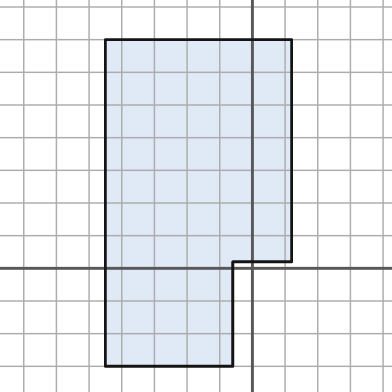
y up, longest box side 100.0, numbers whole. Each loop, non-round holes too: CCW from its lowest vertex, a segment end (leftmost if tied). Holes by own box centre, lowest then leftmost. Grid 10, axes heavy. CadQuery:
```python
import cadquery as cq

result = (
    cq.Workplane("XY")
    .moveTo(-45.0, -30.0)
    .lineTo(-6.0, -30.0)
    .lineTo(-6.0, 2.0)
    .lineTo(12.0, 2.0)
    .lineTo(12.0, 70.0)
    .lineTo(-45.0, 70.0)
    .close()
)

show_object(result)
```